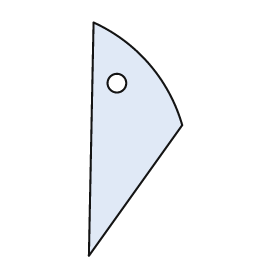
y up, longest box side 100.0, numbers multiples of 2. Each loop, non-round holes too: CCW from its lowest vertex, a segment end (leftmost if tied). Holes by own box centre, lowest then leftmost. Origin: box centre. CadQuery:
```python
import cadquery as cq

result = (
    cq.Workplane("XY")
    .moveTo(-20.0, -50.0)
    .lineTo(20.0, 6.0)
    .threePointArc((6.0, 32.0), (-18.0, 50.0))
    .close()
    .moveTo(-8.0, 24.0)
    .circle(4.0)
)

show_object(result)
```